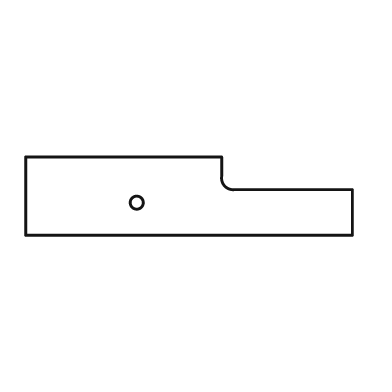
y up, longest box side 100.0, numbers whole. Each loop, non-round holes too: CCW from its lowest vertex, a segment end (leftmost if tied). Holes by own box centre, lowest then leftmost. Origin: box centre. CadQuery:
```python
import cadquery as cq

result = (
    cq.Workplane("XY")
    .moveTo(-50.0, -12.0)
    .lineTo(50.0, -12.0)
    .lineTo(50.0, 2.0)
    .lineTo(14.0, 2.0)
    .threePointArc((11.0, 3.0), (10.0, 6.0))
    .lineTo(10.0, 12.0)
    .lineTo(-50.0, 12.0)
    .close()
    .moveTo(-16.0, -2.0)
    .circle(2.0)
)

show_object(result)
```